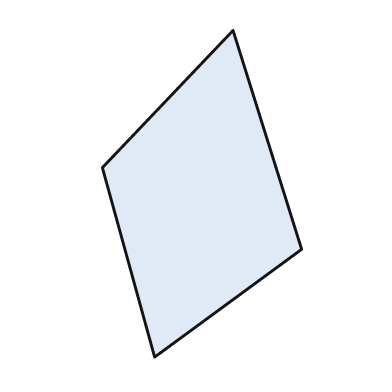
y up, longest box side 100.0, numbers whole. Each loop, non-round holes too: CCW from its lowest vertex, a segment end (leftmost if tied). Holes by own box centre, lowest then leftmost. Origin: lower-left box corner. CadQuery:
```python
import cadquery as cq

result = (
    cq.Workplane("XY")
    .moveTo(16.0, 0.0)
    .lineTo(61.0, 33.0)
    .lineTo(40.0, 100.0)
    .lineTo(0.0, 58.0)
    .close()
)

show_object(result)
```